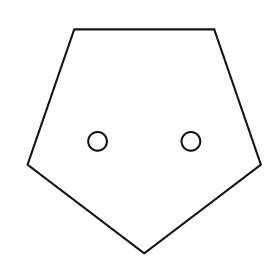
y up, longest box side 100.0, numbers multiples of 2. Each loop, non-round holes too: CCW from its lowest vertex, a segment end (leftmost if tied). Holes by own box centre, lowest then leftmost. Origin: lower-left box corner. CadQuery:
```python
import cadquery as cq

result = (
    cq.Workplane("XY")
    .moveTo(50.0, 0.0)
    .lineTo(100.0, 38.0)
    .lineTo(80.0, 96.0)
    .lineTo(20.0, 96.0)
    .lineTo(0.0, 38.0)
    .close()
    .moveTo(30.0, 48.0)
    .circle(4.0)
    .moveTo(70.0, 48.0)
    .circle(4.0)
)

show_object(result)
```